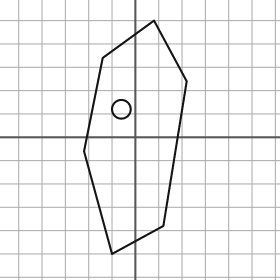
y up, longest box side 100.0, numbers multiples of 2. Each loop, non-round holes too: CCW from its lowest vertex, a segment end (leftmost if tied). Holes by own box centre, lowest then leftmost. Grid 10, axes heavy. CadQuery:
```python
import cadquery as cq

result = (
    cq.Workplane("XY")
    .moveTo(-10.0, -50.0)
    .lineTo(12.0, -38.0)
    .lineTo(22.0, 24.0)
    .lineTo(8.0, 50.0)
    .lineTo(-14.0, 34.0)
    .lineTo(-22.0, -6.0)
    .close()
    .moveTo(-6.0, 12.0)
    .circle(4.0)
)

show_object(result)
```